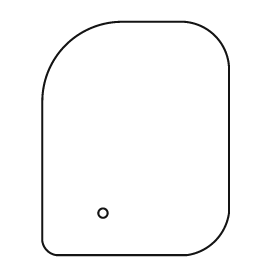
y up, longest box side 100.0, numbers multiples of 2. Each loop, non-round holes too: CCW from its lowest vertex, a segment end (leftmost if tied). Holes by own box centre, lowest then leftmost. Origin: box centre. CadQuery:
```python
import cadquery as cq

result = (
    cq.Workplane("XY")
    .moveTo(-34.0, -50.0)
    .lineTo(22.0, -50.0)
    .threePointArc((34.0, -44.0), (40.0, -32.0))
    .lineTo(40.0, 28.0)
    .threePointArc((34.0, 44.0), (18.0, 50.0))
    .lineTo(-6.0, 50.0)
    .threePointArc((-30.0, 40.0), (-40.0, 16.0))
    .lineTo(-40.0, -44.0)
    .threePointArc((-38.0, -48.0), (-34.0, -50.0))
    .close()
    .moveTo(-14.0, -32.0)
    .circle(2.0)
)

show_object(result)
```